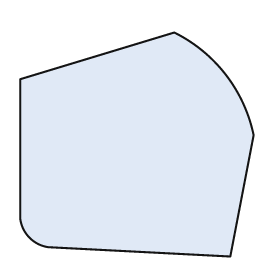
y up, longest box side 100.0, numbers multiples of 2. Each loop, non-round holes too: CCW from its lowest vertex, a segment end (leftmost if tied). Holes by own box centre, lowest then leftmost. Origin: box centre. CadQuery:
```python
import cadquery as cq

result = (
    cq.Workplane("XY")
    .moveTo(40.0, -48.0)
    .lineTo(50.0, 4.0)
    .threePointArc((38.0, 30.0), (16.0, 48.0))
    .lineTo(-50.0, 28.0)
    .lineTo(-50.0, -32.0)
    .threePointArc((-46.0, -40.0), (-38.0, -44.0))
    .close()
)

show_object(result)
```